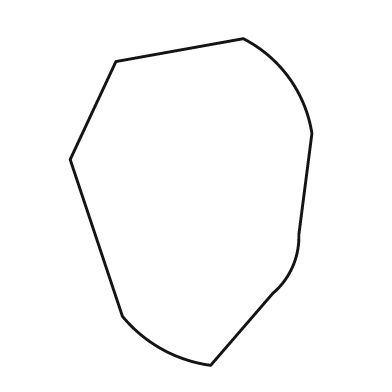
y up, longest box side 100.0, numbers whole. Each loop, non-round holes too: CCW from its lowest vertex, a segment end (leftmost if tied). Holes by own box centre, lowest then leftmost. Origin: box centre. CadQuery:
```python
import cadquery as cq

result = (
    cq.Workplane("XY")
    .moveTo(6.0, -50.0)
    .lineTo(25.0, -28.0)
    .threePointArc((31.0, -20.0), (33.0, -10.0))
    .lineTo(37.0, 21.0)
    .threePointArc((30.0, 38.0), (16.0, 50.0))
    .lineTo(-23.0, 43.0)
    .lineTo(-37.0, 13.0)
    .lineTo(-21.0, -35.0)
    .threePointArc((-9.0, -45.0), (6.0, -50.0))
    .close()
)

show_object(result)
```